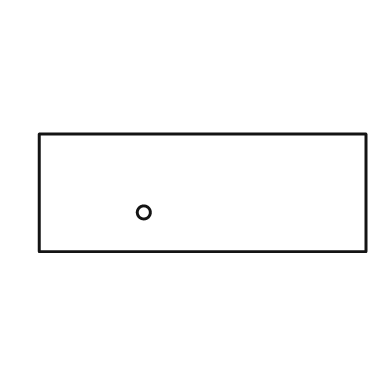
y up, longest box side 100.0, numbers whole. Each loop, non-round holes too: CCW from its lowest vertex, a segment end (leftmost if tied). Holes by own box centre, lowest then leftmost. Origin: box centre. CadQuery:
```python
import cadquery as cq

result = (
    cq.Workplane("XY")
    .moveTo(-50.0, -18.0)
    .lineTo(50.0, -18.0)
    .lineTo(50.0, 18.0)
    .lineTo(-50.0, 18.0)
    .close()
    .moveTo(-18.0, -6.0)
    .circle(2.0)
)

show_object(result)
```